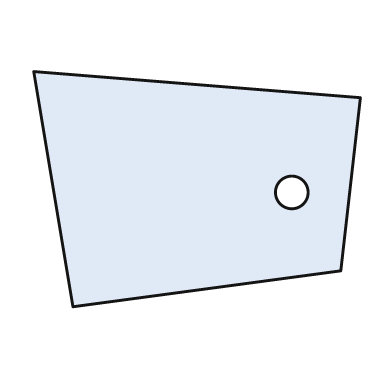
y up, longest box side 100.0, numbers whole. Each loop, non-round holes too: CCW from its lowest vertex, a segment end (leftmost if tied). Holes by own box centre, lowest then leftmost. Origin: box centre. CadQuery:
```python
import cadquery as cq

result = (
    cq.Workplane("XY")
    .moveTo(-38.0, -36.0)
    .lineTo(44.0, -25.0)
    .lineTo(50.0, 28.0)
    .lineTo(-50.0, 36.0)
    .close()
    .moveTo(29.0, -1.0)
    .circle(5.0)
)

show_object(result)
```